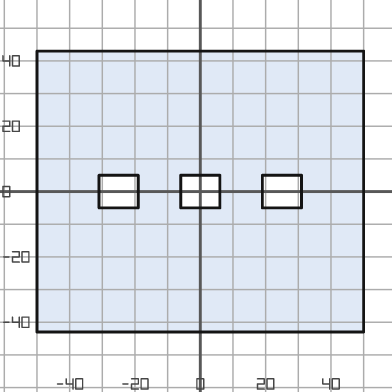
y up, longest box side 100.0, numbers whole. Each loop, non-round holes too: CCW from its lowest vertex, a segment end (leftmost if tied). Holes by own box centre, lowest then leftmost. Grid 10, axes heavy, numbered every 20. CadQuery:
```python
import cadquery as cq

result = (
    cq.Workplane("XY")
    .moveTo(-50.0, -43.0)
    .lineTo(50.0, -43.0)
    .lineTo(50.0, 43.0)
    .lineTo(-50.0, 43.0)
    .close()
    .moveTo(-31.0, -5.0)
    .lineTo(-19.0, -5.0)
    .lineTo(-19.0, 5.0)
    .lineTo(-31.0, 5.0)
    .close()
    .moveTo(-6.0, -5.0)
    .lineTo(6.0, -5.0)
    .lineTo(6.0, 5.0)
    .lineTo(-6.0, 5.0)
    .close()
    .moveTo(19.0, -5.0)
    .lineTo(31.0, -5.0)
    .lineTo(31.0, 5.0)
    .lineTo(19.0, 5.0)
    .close()
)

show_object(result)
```